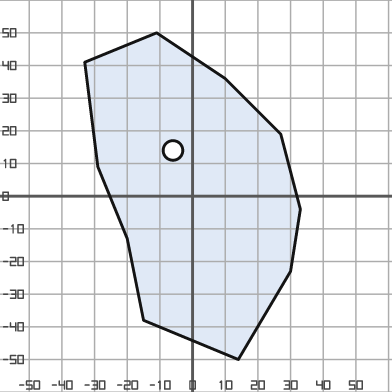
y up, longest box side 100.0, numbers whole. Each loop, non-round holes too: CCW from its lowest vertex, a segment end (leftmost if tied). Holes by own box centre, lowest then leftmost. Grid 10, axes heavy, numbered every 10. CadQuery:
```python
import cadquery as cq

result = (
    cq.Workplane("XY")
    .moveTo(14.0, -50.0)
    .lineTo(30.0, -23.0)
    .lineTo(33.0, -4.0)
    .lineTo(27.0, 19.0)
    .lineTo(10.0, 36.0)
    .lineTo(-11.0, 50.0)
    .lineTo(-33.0, 41.0)
    .lineTo(-29.0, 9.0)
    .lineTo(-20.0, -13.0)
    .lineTo(-15.0, -38.0)
    .close()
    .moveTo(-6.0, 14.0)
    .circle(3.0)
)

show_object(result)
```